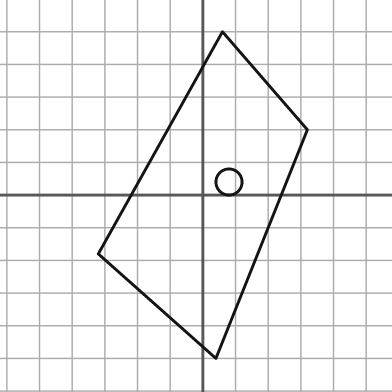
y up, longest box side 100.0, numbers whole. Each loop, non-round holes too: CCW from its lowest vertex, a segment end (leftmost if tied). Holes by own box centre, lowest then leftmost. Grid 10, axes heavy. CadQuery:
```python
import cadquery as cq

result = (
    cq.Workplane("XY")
    .moveTo(4.0, -50.0)
    .lineTo(32.0, 20.0)
    .lineTo(6.0, 50.0)
    .lineTo(-32.0, -18.0)
    .close()
    .moveTo(8.0, 4.0)
    .circle(4.0)
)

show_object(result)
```